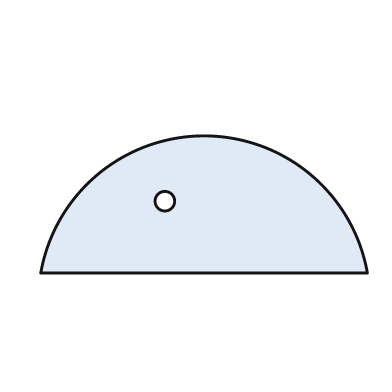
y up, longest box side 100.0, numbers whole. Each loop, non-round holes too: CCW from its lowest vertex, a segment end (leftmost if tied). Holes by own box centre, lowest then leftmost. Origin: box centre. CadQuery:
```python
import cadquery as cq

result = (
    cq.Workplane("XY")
    .moveTo(-50.0, -21.0)
    .lineTo(50.0, -21.0)
    .threePointArc((0.0, 21.0), (-50.0, -21.0))
    .close()
    .moveTo(-12.0, 1.0)
    .circle(3.0)
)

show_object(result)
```